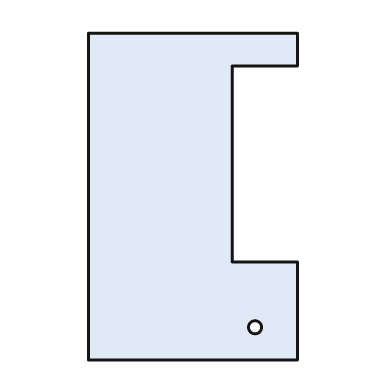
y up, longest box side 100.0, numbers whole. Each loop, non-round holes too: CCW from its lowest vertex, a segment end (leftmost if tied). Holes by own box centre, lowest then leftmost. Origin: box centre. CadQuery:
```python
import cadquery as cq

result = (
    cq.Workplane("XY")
    .moveTo(-32.0, -50.0)
    .lineTo(32.0, -50.0)
    .lineTo(32.0, -20.0)
    .lineTo(12.0, -20.0)
    .lineTo(12.0, 40.0)
    .lineTo(32.0, 40.0)
    .lineTo(32.0, 50.0)
    .lineTo(-32.0, 50.0)
    .close()
    .moveTo(19.0, -40.0)
    .circle(2.0)
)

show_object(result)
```